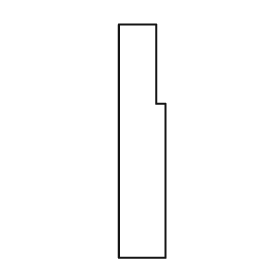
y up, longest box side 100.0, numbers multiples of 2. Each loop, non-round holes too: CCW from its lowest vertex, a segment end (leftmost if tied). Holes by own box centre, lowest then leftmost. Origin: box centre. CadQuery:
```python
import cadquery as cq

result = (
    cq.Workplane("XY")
    .moveTo(-10.0, -50.0)
    .lineTo(10.0, -50.0)
    .lineTo(10.0, 16.0)
    .lineTo(6.0, 16.0)
    .lineTo(6.0, 50.0)
    .lineTo(-10.0, 50.0)
    .close()
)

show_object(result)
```